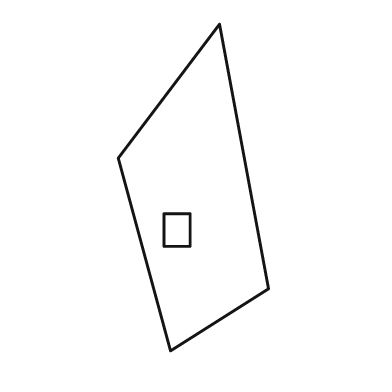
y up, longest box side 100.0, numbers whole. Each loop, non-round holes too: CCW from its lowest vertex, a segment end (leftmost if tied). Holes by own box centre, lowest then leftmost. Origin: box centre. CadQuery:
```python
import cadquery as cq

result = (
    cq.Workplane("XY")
    .moveTo(-7.0, -50.0)
    .lineTo(23.0, -31.0)
    .lineTo(8.0, 50.0)
    .lineTo(-23.0, 9.0)
    .close()
    .moveTo(-9.0, -18.0)
    .lineTo(-1.0, -18.0)
    .lineTo(-1.0, -8.0)
    .lineTo(-9.0, -8.0)
    .close()
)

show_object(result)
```